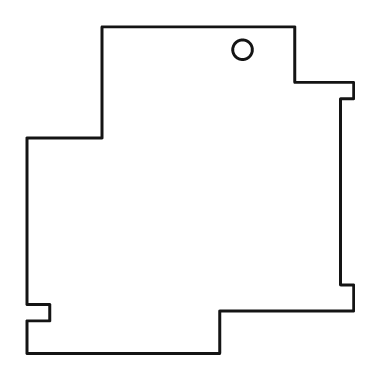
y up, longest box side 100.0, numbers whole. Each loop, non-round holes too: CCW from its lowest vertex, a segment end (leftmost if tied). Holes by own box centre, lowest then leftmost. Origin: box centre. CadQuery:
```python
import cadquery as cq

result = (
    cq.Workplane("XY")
    .moveTo(-50.0, -50.0)
    .lineTo(9.0, -50.0)
    .lineTo(9.0, -37.0)
    .lineTo(50.0, -37.0)
    .lineTo(50.0, -29.0)
    .lineTo(46.0, -29.0)
    .lineTo(46.0, 28.0)
    .lineTo(50.0, 28.0)
    .lineTo(50.0, 33.0)
    .lineTo(32.0, 33.0)
    .lineTo(32.0, 50.0)
    .lineTo(-27.0, 50.0)
    .lineTo(-27.0, 16.0)
    .lineTo(-50.0, 16.0)
    .lineTo(-50.0, -35.0)
    .lineTo(-43.0, -35.0)
    .lineTo(-43.0, -40.0)
    .lineTo(-50.0, -40.0)
    .close()
    .moveTo(16.0, 43.0)
    .circle(3.0)
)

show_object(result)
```